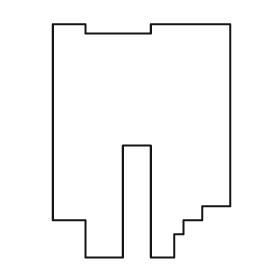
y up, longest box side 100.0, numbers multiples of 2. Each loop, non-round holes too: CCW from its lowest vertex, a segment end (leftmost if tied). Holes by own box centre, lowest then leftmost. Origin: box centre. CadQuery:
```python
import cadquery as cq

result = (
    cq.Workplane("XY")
    .moveTo(-24.0, -50.0)
    .lineTo(-8.0, -50.0)
    .lineTo(-8.0, -2.0)
    .lineTo(4.0, -2.0)
    .lineTo(4.0, -50.0)
    .lineTo(14.0, -50.0)
    .lineTo(14.0, -40.0)
    .lineTo(18.0, -40.0)
    .lineTo(18.0, -34.0)
    .lineTo(26.0, -34.0)
    .lineTo(26.0, -28.0)
    .lineTo(38.0, -28.0)
    .lineTo(38.0, 50.0)
    .lineTo(4.0, 50.0)
    .lineTo(4.0, 46.0)
    .lineTo(-24.0, 46.0)
    .lineTo(-24.0, 50.0)
    .lineTo(-38.0, 50.0)
    .lineTo(-38.0, -34.0)
    .lineTo(-24.0, -34.0)
    .close()
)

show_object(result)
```